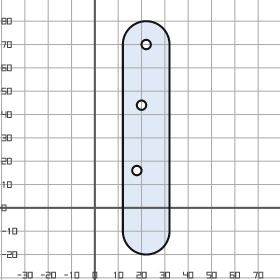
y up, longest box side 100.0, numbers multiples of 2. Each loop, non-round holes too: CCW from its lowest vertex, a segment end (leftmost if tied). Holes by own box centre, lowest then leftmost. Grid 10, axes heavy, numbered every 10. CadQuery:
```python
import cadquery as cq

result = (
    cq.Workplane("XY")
    .moveTo(12.0, -10.0)
    .threePointArc((22.0, -20.0), (32.0, -10.0))
    .lineTo(32.0, 70.0)
    .threePointArc((22.0, 80.0), (12.0, 70.0))
    .close()
    .moveTo(18.0, 16.0)
    .circle(2.0)
    .moveTo(20.0, 44.0)
    .circle(2.0)
    .moveTo(22.0, 70.0)
    .circle(2.0)
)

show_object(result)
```